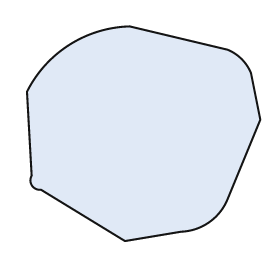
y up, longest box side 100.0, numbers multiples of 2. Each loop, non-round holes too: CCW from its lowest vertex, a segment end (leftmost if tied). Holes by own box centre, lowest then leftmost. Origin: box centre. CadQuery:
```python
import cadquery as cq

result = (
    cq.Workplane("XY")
    .moveTo(-8.0, -46.0)
    .lineTo(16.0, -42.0)
    .threePointArc((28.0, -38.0), (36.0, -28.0))
    .lineTo(50.0, 6.0)
    .lineTo(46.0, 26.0)
    .threePointArc((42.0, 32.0), (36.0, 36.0))
    .lineTo(-6.0, 46.0)
    .threePointArc((-32.0, 38.0), (-50.0, 18.0))
    .lineTo(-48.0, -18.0)
    .threePointArc((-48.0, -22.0), (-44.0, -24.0))
    .close()
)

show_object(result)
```